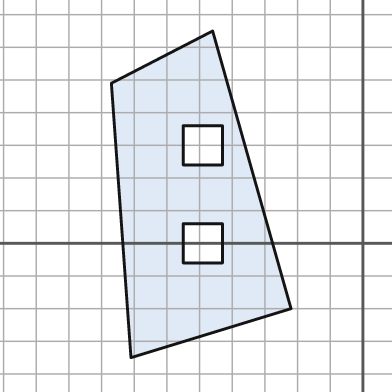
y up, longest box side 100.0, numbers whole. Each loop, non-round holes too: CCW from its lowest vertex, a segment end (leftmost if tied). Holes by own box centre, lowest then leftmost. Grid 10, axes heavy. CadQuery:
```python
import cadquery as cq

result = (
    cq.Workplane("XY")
    .moveTo(-71.0, -35.0)
    .lineTo(-22.0, -20.0)
    .lineTo(-46.0, 65.0)
    .lineTo(-77.0, 49.0)
    .close()
    .moveTo(-55.0, -6.0)
    .lineTo(-43.0, -6.0)
    .lineTo(-43.0, 6.0)
    .lineTo(-55.0, 6.0)
    .close()
    .moveTo(-55.0, 24.0)
    .lineTo(-43.0, 24.0)
    .lineTo(-43.0, 36.0)
    .lineTo(-55.0, 36.0)
    .close()
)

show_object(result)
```